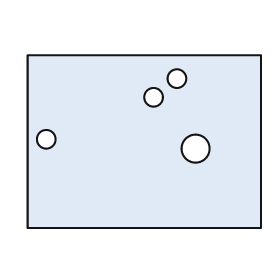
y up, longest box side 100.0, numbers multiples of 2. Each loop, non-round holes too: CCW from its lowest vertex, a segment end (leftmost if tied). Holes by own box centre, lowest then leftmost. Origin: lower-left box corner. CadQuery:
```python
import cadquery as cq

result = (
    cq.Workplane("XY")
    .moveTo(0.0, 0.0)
    .lineTo(100.0, 0.0)
    .lineTo(100.0, 74.0)
    .lineTo(0.0, 74.0)
    .close()
    .moveTo(72.0, 34.0)
    .circle(6.0)
    .moveTo(8.0, 38.0)
    .circle(4.0)
    .moveTo(54.0, 56.0)
    .circle(4.0)
    .moveTo(64.0, 64.0)
    .circle(4.0)
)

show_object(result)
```